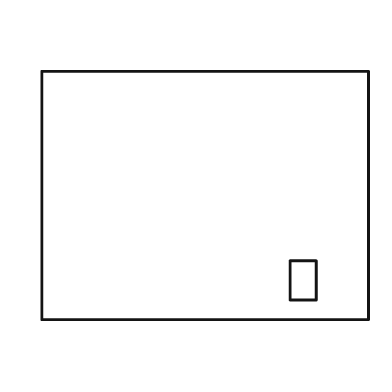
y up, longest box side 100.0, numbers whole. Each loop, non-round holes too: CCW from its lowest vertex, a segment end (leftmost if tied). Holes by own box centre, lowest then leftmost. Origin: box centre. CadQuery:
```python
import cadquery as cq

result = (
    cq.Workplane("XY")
    .moveTo(-50.0, -38.0)
    .lineTo(50.0, -38.0)
    .lineTo(50.0, 38.0)
    .lineTo(-50.0, 38.0)
    .close()
    .moveTo(26.0, -32.0)
    .lineTo(34.0, -32.0)
    .lineTo(34.0, -20.0)
    .lineTo(26.0, -20.0)
    .close()
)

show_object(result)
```